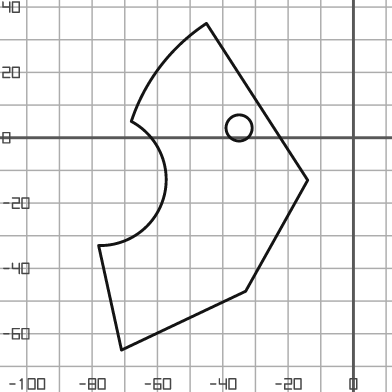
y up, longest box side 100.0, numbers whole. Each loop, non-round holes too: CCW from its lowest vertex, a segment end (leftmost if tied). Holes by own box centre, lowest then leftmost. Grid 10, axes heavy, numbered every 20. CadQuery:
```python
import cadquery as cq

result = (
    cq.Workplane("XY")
    .moveTo(-71.0, -65.0)
    .lineTo(-33.0, -47.0)
    .lineTo(-14.0, -13.0)
    .lineTo(-45.0, 35.0)
    .threePointArc((-59.0, 22.0), (-68.0, 5.0))
    .threePointArc((-58.0, -18.0), (-78.0, -33.0))
    .close()
    .moveTo(-35.0, 3.0)
    .circle(4.0)
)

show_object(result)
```